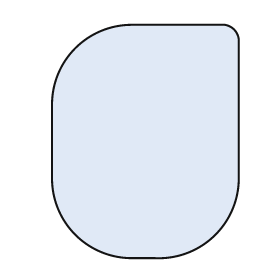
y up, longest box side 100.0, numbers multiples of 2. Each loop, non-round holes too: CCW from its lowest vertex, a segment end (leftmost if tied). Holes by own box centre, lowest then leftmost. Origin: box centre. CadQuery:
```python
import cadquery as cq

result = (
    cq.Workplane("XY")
    .moveTo(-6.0, -50.0)
    .lineTo(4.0, -50.0)
    .threePointArc((30.0, -40.0), (40.0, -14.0))
    .lineTo(40.0, 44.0)
    .threePointArc((38.0, 48.0), (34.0, 50.0))
    .lineTo(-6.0, 50.0)
    .threePointArc((-30.0, 40.0), (-40.0, 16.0))
    .lineTo(-40.0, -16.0)
    .threePointArc((-30.0, -40.0), (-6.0, -50.0))
    .close()
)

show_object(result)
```